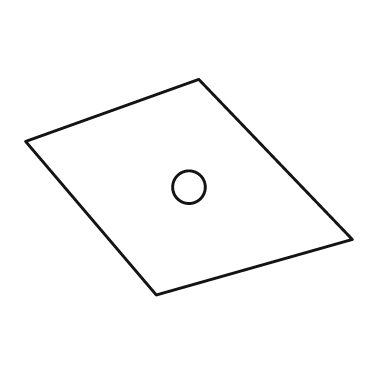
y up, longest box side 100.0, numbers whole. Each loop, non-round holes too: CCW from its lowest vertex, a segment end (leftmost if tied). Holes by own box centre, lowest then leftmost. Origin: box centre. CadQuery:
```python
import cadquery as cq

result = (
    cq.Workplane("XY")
    .moveTo(-10.0, -33.0)
    .lineTo(50.0, -16.0)
    .lineTo(3.0, 33.0)
    .lineTo(-50.0, 14.0)
    .close()
    .moveTo(0.0, 0.0)
    .circle(5.0)
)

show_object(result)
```